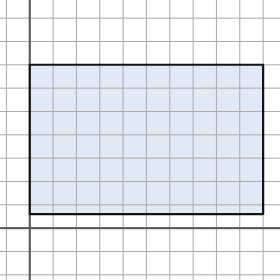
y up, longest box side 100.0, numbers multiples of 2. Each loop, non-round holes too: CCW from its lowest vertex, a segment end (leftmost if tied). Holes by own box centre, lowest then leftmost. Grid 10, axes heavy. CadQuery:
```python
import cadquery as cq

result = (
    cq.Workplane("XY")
    .moveTo(0.0, 6.0)
    .lineTo(100.0, 6.0)
    .lineTo(100.0, 70.0)
    .lineTo(0.0, 70.0)
    .close()
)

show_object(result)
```